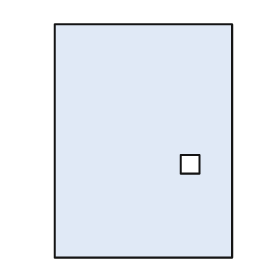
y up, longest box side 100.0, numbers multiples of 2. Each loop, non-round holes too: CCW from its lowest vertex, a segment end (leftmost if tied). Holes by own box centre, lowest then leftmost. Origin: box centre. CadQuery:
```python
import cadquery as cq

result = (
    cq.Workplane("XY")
    .moveTo(-38.0, -50.0)
    .lineTo(38.0, -50.0)
    .lineTo(38.0, 50.0)
    .lineTo(-38.0, 50.0)
    .close()
    .moveTo(16.0, -14.0)
    .lineTo(24.0, -14.0)
    .lineTo(24.0, -6.0)
    .lineTo(16.0, -6.0)
    .close()
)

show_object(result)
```